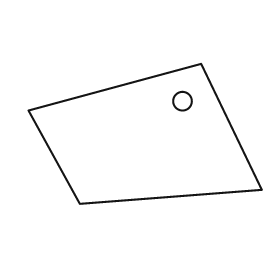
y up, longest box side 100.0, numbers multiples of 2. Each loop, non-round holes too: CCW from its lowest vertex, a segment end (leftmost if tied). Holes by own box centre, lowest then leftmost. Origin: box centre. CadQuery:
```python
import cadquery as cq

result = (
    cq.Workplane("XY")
    .moveTo(-28.0, -30.0)
    .lineTo(50.0, -24.0)
    .lineTo(24.0, 30.0)
    .lineTo(-50.0, 10.0)
    .close()
    .moveTo(16.0, 14.0)
    .circle(4.0)
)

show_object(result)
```